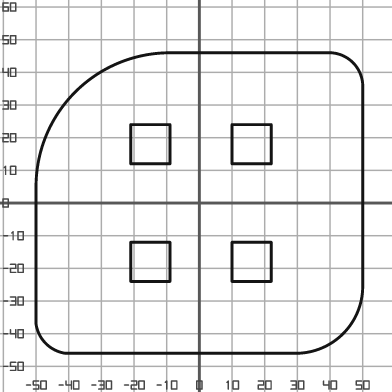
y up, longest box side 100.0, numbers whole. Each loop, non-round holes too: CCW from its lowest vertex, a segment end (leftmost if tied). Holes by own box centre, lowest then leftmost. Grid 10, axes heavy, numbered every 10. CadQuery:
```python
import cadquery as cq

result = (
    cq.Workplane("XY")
    .moveTo(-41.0, -46.0)
    .lineTo(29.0, -46.0)
    .threePointArc((44.0, -40.0), (50.0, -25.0))
    .lineTo(50.0, 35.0)
    .threePointArc((47.0, 43.0), (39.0, 46.0))
    .lineTo(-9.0, 46.0)
    .threePointArc((-38.0, 34.0), (-50.0, 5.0))
    .lineTo(-50.0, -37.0)
    .threePointArc((-47.0, -43.0), (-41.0, -46.0))
    .close()
    .moveTo(-21.0, -24.0)
    .lineTo(-9.0, -24.0)
    .lineTo(-9.0, -12.0)
    .lineTo(-21.0, -12.0)
    .close()
    .moveTo(10.0, -24.0)
    .lineTo(22.0, -24.0)
    .lineTo(22.0, -12.0)
    .lineTo(10.0, -12.0)
    .close()
    .moveTo(-21.0, 12.0)
    .lineTo(-9.0, 12.0)
    .lineTo(-9.0, 24.0)
    .lineTo(-21.0, 24.0)
    .close()
    .moveTo(10.0, 12.0)
    .lineTo(22.0, 12.0)
    .lineTo(22.0, 24.0)
    .lineTo(10.0, 24.0)
    .close()
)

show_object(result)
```